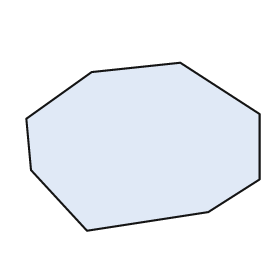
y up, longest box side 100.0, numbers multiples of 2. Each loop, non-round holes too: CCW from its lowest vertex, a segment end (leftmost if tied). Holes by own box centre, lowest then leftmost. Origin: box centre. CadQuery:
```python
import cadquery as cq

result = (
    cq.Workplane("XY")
    .moveTo(-24.0, -36.0)
    .lineTo(28.0, -28.0)
    .lineTo(50.0, -14.0)
    .lineTo(50.0, 14.0)
    .lineTo(16.0, 36.0)
    .lineTo(-22.0, 32.0)
    .lineTo(-50.0, 12.0)
    .lineTo(-48.0, -10.0)
    .close()
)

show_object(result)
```